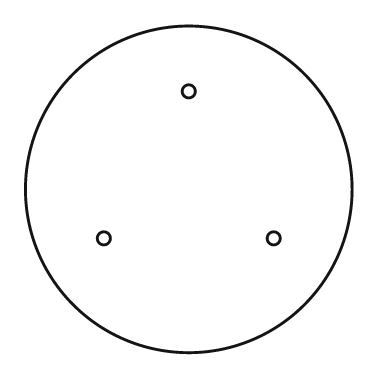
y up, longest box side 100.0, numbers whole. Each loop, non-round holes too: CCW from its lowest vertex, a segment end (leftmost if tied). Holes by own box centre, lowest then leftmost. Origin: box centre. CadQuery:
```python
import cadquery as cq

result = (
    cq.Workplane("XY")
    .moveTo(0.0, 0.0)
    .circle(50.0)
    .moveTo(-26.0, -15.0)
    .circle(2.0)
    .moveTo(26.0, -15.0)
    .circle(2.0)
    .moveTo(0.0, 30.0)
    .circle(2.0)
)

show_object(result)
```